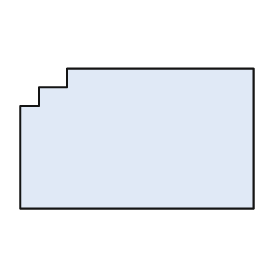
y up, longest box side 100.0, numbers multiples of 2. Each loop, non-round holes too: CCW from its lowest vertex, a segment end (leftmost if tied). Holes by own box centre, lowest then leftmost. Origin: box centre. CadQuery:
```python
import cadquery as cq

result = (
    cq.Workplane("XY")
    .moveTo(-50.0, -30.0)
    .lineTo(50.0, -30.0)
    .lineTo(50.0, 30.0)
    .lineTo(-30.0, 30.0)
    .lineTo(-30.0, 22.0)
    .lineTo(-42.0, 22.0)
    .lineTo(-42.0, 14.0)
    .lineTo(-50.0, 14.0)
    .close()
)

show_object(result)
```